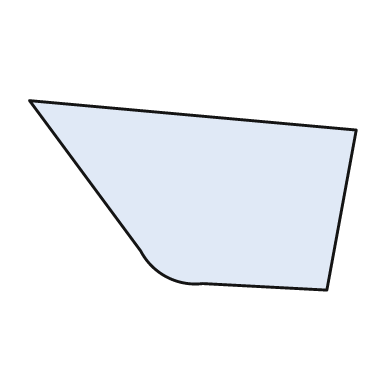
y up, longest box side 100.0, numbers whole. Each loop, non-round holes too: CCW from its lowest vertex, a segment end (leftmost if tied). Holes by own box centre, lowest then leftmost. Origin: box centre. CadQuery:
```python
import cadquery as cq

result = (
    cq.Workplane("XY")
    .moveTo(41.0, -29.0)
    .lineTo(50.0, 20.0)
    .lineTo(-50.0, 29.0)
    .lineTo(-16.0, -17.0)
    .threePointArc((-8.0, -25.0), (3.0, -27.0))
    .close()
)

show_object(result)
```